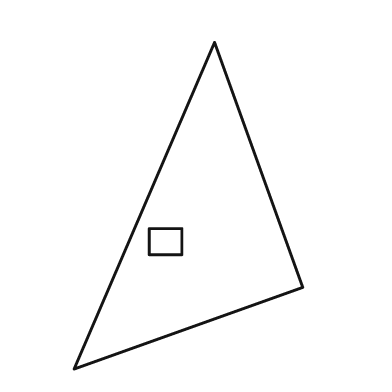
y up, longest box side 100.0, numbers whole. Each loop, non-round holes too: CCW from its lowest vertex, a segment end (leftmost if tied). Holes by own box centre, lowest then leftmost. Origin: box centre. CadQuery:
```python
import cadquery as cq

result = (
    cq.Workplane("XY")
    .moveTo(-35.0, -50.0)
    .lineTo(35.0, -25.0)
    .lineTo(8.0, 50.0)
    .close()
    .moveTo(-12.0, -15.0)
    .lineTo(-2.0, -15.0)
    .lineTo(-2.0, -7.0)
    .lineTo(-12.0, -7.0)
    .close()
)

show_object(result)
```